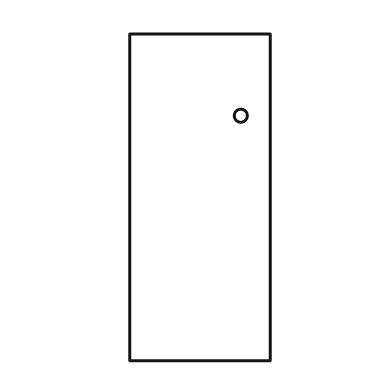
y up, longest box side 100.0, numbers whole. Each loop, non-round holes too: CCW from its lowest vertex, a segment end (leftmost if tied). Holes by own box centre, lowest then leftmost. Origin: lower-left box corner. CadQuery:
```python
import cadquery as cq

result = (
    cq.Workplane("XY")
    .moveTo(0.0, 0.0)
    .lineTo(43.0, 0.0)
    .lineTo(43.0, 100.0)
    .lineTo(0.0, 100.0)
    .close()
    .moveTo(34.0, 75.0)
    .circle(2.0)
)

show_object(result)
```